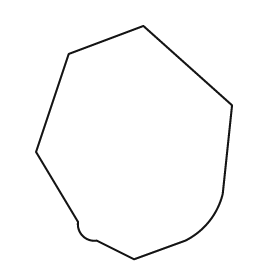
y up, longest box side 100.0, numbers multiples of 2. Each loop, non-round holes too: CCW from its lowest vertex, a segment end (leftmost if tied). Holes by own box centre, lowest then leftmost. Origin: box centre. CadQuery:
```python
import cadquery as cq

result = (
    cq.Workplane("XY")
    .moveTo(0.0, -50.0)
    .lineTo(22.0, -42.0)
    .threePointArc((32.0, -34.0), (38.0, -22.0))
    .lineTo(42.0, 16.0)
    .lineTo(4.0, 50.0)
    .lineTo(-28.0, 38.0)
    .lineTo(-42.0, -4.0)
    .lineTo(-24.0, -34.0)
    .threePointArc((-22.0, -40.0), (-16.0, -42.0))
    .close()
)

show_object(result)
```